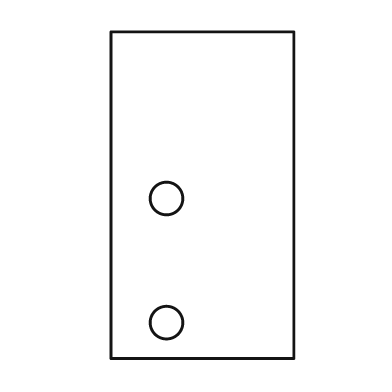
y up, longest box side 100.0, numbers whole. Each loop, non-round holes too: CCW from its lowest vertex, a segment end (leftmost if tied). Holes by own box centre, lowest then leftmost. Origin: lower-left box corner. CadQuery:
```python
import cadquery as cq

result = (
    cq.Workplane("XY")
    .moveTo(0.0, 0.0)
    .lineTo(56.0, 0.0)
    .lineTo(56.0, 100.0)
    .lineTo(0.0, 100.0)
    .close()
    .moveTo(17.0, 11.0)
    .circle(5.0)
    .moveTo(17.0, 49.0)
    .circle(5.0)
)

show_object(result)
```